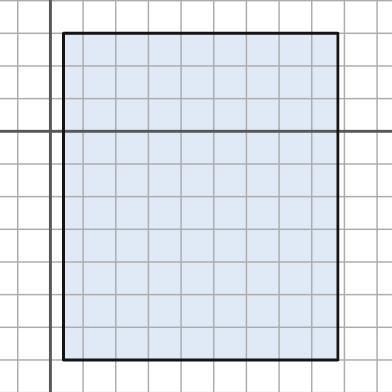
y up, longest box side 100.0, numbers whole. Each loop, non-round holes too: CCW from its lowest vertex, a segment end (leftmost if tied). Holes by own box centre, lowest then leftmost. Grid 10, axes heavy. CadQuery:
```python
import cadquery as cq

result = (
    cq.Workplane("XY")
    .moveTo(4.0, -70.0)
    .lineTo(88.0, -70.0)
    .lineTo(88.0, 30.0)
    .lineTo(4.0, 30.0)
    .close()
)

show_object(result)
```